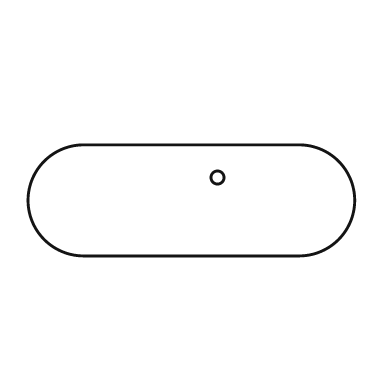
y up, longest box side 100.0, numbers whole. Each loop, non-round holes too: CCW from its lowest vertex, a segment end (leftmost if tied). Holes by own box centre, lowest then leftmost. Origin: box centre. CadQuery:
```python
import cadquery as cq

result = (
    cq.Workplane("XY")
    .moveTo(-33.0, -17.0)
    .lineTo(33.0, -17.0)
    .threePointArc((50.0, 0.0), (33.0, 17.0))
    .lineTo(-33.0, 17.0)
    .threePointArc((-50.0, 0.0), (-33.0, -17.0))
    .close()
    .moveTo(8.0, 7.0)
    .circle(2.0)
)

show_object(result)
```